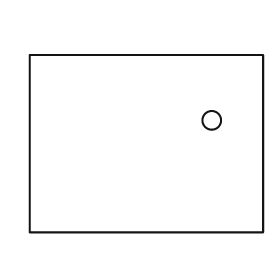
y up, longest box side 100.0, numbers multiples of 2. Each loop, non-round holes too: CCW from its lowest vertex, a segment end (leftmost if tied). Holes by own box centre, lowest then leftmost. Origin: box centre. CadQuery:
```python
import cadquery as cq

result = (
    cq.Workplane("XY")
    .moveTo(-50.0, -38.0)
    .lineTo(50.0, -38.0)
    .lineTo(50.0, 38.0)
    .lineTo(-50.0, 38.0)
    .close()
    .moveTo(28.0, 10.0)
    .circle(4.0)
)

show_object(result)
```